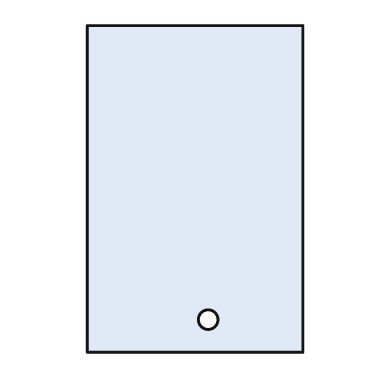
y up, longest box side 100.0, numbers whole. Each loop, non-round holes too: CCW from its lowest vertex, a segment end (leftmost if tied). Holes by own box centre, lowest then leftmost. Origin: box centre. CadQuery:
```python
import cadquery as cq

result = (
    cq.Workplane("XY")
    .moveTo(-33.0, -50.0)
    .lineTo(33.0, -50.0)
    .lineTo(33.0, 50.0)
    .lineTo(-33.0, 50.0)
    .close()
    .moveTo(4.0, -40.0)
    .circle(3.0)
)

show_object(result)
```